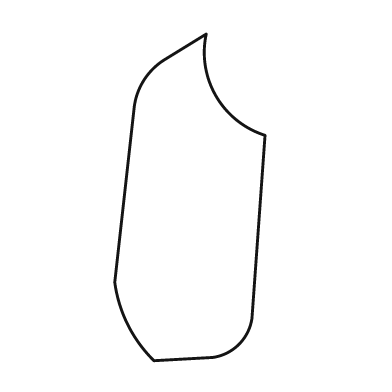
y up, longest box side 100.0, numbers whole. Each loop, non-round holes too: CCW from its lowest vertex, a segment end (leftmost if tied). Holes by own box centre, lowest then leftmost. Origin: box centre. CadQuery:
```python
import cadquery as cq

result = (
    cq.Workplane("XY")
    .moveTo(-11.0, -50.0)
    .lineTo(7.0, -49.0)
    .threePointArc((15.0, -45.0), (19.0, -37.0))
    .lineTo(23.0, 19.0)
    .threePointArc((8.0, 31.0), (5.0, 50.0))
    .lineTo(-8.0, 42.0)
    .threePointArc((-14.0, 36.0), (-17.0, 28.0))
    .lineTo(-23.0, -26.0)
    .threePointArc((-19.0, -39.0), (-11.0, -50.0))
    .close()
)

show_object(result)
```